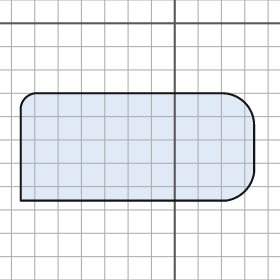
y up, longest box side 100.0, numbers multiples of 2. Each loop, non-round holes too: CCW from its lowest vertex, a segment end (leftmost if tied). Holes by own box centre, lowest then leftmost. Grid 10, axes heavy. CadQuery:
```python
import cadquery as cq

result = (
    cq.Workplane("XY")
    .moveTo(-66.0, -76.0)
    .lineTo(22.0, -76.0)
    .threePointArc((30.0, -72.0), (34.0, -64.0))
    .lineTo(34.0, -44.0)
    .threePointArc((30.0, -34.0), (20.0, -30.0))
    .lineTo(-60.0, -30.0)
    .threePointArc((-64.0, -32.0), (-66.0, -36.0))
    .close()
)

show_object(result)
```